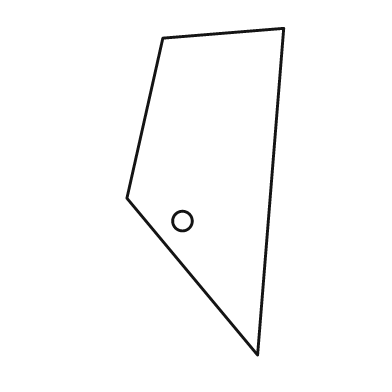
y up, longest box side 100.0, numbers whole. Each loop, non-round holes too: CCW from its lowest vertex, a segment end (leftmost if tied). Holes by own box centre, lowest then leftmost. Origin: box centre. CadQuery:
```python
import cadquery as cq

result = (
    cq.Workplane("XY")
    .moveTo(16.0, -50.0)
    .lineTo(24.0, 50.0)
    .lineTo(-13.0, 47.0)
    .lineTo(-24.0, -2.0)
    .close()
    .moveTo(-7.0, -9.0)
    .circle(3.0)
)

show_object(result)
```